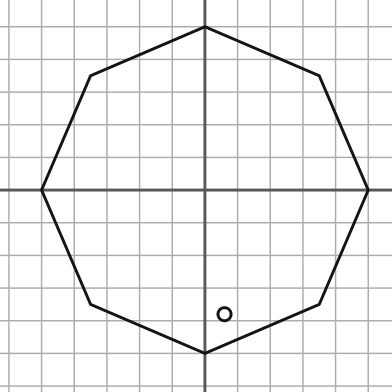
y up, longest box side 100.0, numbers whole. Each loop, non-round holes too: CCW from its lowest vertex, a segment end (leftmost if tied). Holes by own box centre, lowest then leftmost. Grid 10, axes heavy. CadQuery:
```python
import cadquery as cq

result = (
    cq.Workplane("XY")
    .moveTo(0.0, -50.0)
    .lineTo(35.0, -35.0)
    .lineTo(50.0, 0.0)
    .lineTo(35.0, 35.0)
    .lineTo(0.0, 50.0)
    .lineTo(-35.0, 35.0)
    .lineTo(-50.0, 0.0)
    .lineTo(-35.0, -35.0)
    .close()
    .moveTo(6.0, -38.0)
    .circle(2.0)
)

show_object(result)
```